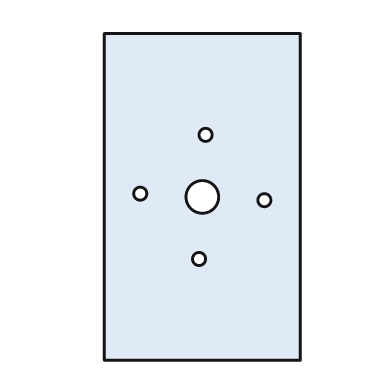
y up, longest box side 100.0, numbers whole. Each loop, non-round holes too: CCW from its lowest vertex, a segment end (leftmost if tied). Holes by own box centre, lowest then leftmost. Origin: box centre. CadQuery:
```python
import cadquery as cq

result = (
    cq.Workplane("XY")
    .moveTo(-30.0, -50.0)
    .lineTo(30.0, -50.0)
    .lineTo(30.0, 50.0)
    .lineTo(-30.0, 50.0)
    .close()
    .moveTo(-1.0, -19.0)
    .circle(2.0)
    .moveTo(19.0, -1.0)
    .circle(2.0)
    .moveTo(0.0, 0.0)
    .circle(5.0)
    .moveTo(-19.0, 1.0)
    .circle(2.0)
    .moveTo(1.0, 19.0)
    .circle(2.0)
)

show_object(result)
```